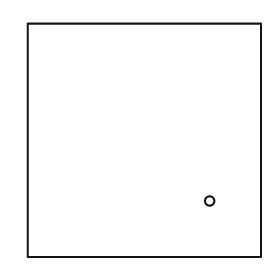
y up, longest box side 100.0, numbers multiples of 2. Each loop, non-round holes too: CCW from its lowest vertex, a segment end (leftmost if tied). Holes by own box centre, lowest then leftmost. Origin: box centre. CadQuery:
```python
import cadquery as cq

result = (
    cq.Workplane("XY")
    .moveTo(-50.0, -50.0)
    .lineTo(50.0, -50.0)
    .lineTo(50.0, 50.0)
    .lineTo(-50.0, 50.0)
    .close()
    .moveTo(28.0, -26.0)
    .circle(2.0)
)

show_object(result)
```